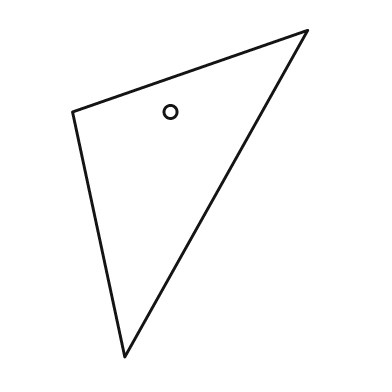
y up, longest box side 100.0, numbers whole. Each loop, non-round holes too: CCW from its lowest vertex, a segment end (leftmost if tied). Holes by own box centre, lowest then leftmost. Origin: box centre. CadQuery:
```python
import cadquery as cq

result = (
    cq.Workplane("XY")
    .moveTo(-20.0, -50.0)
    .lineTo(36.0, 50.0)
    .lineTo(-36.0, 25.0)
    .close()
    .moveTo(-6.0, 25.0)
    .circle(2.0)
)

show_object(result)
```